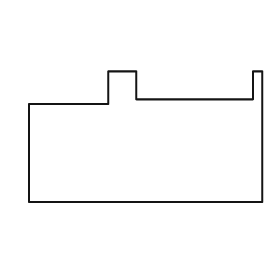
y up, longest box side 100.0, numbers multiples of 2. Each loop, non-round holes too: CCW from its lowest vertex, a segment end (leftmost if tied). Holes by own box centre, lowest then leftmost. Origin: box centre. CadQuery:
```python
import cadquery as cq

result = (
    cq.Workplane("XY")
    .moveTo(-50.0, -28.0)
    .lineTo(50.0, -28.0)
    .lineTo(50.0, 28.0)
    .lineTo(46.0, 28.0)
    .lineTo(46.0, 16.0)
    .lineTo(-4.0, 16.0)
    .lineTo(-4.0, 28.0)
    .lineTo(-16.0, 28.0)
    .lineTo(-16.0, 14.0)
    .lineTo(-50.0, 14.0)
    .close()
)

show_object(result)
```